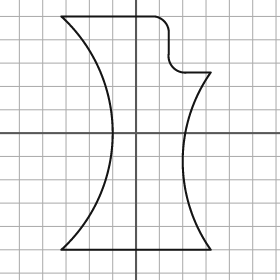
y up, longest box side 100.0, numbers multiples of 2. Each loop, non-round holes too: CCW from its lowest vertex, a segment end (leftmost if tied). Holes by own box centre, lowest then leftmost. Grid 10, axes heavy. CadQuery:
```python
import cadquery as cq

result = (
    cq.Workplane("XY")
    .moveTo(-32.0, -50.0)
    .lineTo(32.0, -50.0)
    .threePointArc((20.0, -12.0), (32.0, 26.0))
    .lineTo(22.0, 26.0)
    .threePointArc((16.0, 28.0), (14.0, 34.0))
    .lineTo(14.0, 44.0)
    .threePointArc((12.0, 48.0), (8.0, 50.0))
    .lineTo(-32.0, 50.0)
    .threePointArc((-10.0, 0.0), (-32.0, -50.0))
    .close()
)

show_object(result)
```